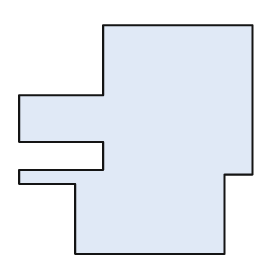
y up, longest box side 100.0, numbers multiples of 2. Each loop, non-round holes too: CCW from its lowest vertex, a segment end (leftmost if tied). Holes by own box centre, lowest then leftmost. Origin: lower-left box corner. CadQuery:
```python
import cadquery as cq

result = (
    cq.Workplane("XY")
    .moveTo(24.0, 0.0)
    .lineTo(88.0, 0.0)
    .lineTo(88.0, 34.0)
    .lineTo(100.0, 34.0)
    .lineTo(100.0, 98.0)
    .lineTo(36.0, 98.0)
    .lineTo(36.0, 68.0)
    .lineTo(0.0, 68.0)
    .lineTo(0.0, 48.0)
    .lineTo(36.0, 48.0)
    .lineTo(36.0, 36.0)
    .lineTo(0.0, 36.0)
    .lineTo(0.0, 30.0)
    .lineTo(24.0, 30.0)
    .close()
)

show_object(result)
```